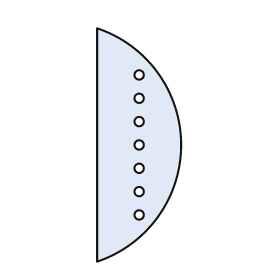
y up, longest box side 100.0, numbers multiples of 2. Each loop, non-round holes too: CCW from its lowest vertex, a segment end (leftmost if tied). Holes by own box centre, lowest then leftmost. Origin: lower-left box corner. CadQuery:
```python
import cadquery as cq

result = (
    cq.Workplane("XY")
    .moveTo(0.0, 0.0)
    .threePointArc((36.0, 50.0), (0.0, 100.0))
    .close()
    .moveTo(18.0, 20.0)
    .circle(2.0)
    .moveTo(18.0, 30.0)
    .circle(2.0)
    .moveTo(18.0, 40.0)
    .circle(2.0)
    .moveTo(18.0, 50.0)
    .circle(2.0)
    .moveTo(18.0, 60.0)
    .circle(2.0)
    .moveTo(18.0, 70.0)
    .circle(2.0)
    .moveTo(18.0, 80.0)
    .circle(2.0)
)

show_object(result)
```